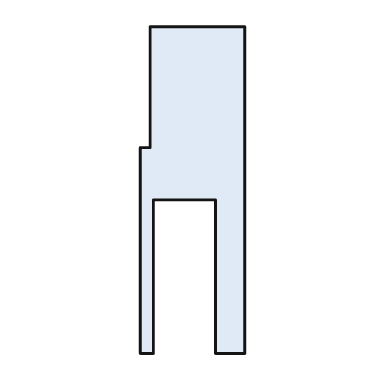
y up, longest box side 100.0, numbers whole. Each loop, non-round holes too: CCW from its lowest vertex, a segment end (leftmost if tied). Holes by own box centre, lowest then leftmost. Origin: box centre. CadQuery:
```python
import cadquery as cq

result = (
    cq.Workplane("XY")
    .moveTo(-16.0, -50.0)
    .lineTo(-12.0, -50.0)
    .lineTo(-12.0, -3.0)
    .lineTo(7.0, -3.0)
    .lineTo(7.0, -50.0)
    .lineTo(16.0, -50.0)
    .lineTo(16.0, 50.0)
    .lineTo(-13.0, 50.0)
    .lineTo(-13.0, 13.0)
    .lineTo(-16.0, 13.0)
    .close()
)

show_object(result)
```